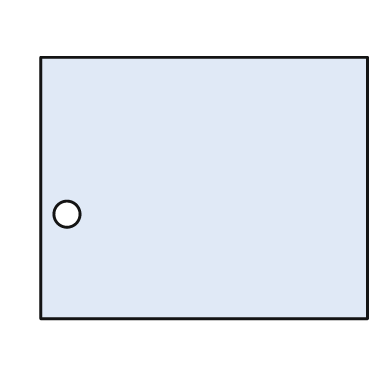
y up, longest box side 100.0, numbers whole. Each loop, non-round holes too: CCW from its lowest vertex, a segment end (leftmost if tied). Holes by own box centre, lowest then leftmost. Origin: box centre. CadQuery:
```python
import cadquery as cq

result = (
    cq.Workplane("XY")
    .moveTo(-50.0, -40.0)
    .lineTo(50.0, -40.0)
    .lineTo(50.0, 40.0)
    .lineTo(-50.0, 40.0)
    .close()
    .moveTo(-42.0, -8.0)
    .circle(4.0)
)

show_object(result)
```